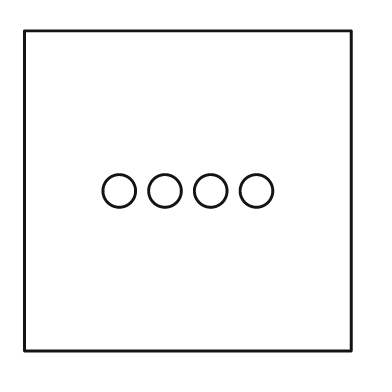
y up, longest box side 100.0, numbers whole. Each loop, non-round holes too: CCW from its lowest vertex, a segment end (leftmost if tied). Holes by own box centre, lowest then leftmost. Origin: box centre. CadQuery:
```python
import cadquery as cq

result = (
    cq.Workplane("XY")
    .moveTo(-50.0, -49.0)
    .lineTo(50.0, -49.0)
    .lineTo(50.0, 49.0)
    .lineTo(-50.0, 49.0)
    .close()
    .moveTo(-21.0, 0.0)
    .circle(5.0)
    .moveTo(-7.0, 0.0)
    .circle(5.0)
    .moveTo(7.0, 0.0)
    .circle(5.0)
    .moveTo(21.0, 0.0)
    .circle(5.0)
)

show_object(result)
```